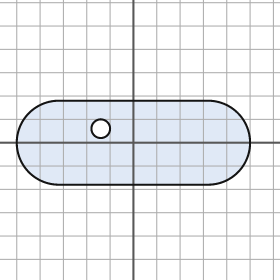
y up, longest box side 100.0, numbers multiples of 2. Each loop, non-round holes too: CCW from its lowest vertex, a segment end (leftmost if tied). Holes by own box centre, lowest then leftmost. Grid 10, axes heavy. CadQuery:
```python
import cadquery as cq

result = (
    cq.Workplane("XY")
    .moveTo(-32.0, -18.0)
    .lineTo(32.0, -18.0)
    .threePointArc((50.0, 0.0), (32.0, 18.0))
    .lineTo(-32.0, 18.0)
    .threePointArc((-50.0, 0.0), (-32.0, -18.0))
    .close()
    .moveTo(-14.0, 6.0)
    .circle(4.0)
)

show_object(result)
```